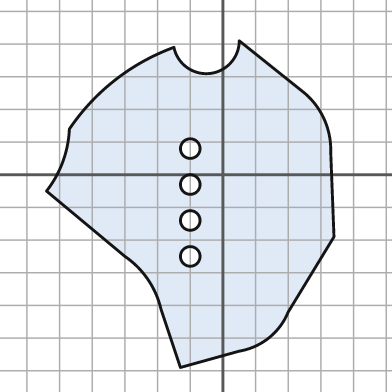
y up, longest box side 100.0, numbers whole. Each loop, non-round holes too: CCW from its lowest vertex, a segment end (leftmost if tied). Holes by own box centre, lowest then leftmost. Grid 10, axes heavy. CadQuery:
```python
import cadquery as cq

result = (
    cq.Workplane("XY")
    .moveTo(-13.0, -59.0)
    .lineTo(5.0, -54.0)
    .threePointArc((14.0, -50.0), (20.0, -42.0))
    .lineTo(34.0, -19.0)
    .lineTo(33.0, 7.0)
    .threePointArc((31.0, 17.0), (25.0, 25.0))
    .lineTo(5.0, 41.0)
    .threePointArc((-4.0, 31.0), (-15.0, 39.0))
    .threePointArc((-33.0, 29.0), (-47.0, 14.0))
    .threePointArc((-49.0, 4.0), (-54.0, -5.0))
    .lineTo(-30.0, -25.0)
    .threePointArc((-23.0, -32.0), (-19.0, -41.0))
    .close()
    .moveTo(-10.0, -25.0)
    .circle(3.0)
    .moveTo(-10.0, -14.0)
    .circle(3.0)
    .moveTo(-10.0, -3.0)
    .circle(3.0)
    .moveTo(-10.0, 8.0)
    .circle(3.0)
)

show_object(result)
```